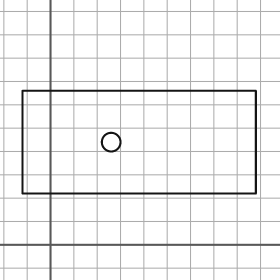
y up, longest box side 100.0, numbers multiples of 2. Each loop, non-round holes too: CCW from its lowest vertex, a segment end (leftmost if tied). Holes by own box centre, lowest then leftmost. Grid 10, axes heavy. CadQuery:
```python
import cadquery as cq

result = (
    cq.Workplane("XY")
    .moveTo(-12.0, 22.0)
    .lineTo(88.0, 22.0)
    .lineTo(88.0, 66.0)
    .lineTo(-12.0, 66.0)
    .close()
    .moveTo(26.0, 44.0)
    .circle(4.0)
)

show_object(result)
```